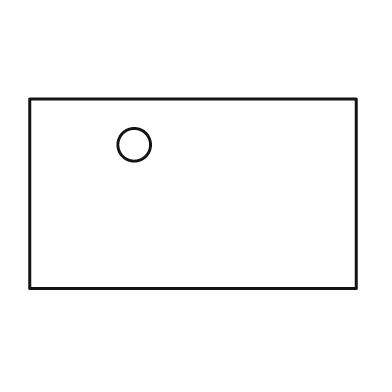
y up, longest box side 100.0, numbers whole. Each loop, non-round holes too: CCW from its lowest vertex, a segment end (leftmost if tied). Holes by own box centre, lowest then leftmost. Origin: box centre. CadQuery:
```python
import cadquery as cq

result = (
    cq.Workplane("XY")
    .moveTo(-50.0, -29.0)
    .lineTo(50.0, -29.0)
    .lineTo(50.0, 29.0)
    .lineTo(-50.0, 29.0)
    .close()
    .moveTo(-18.0, 15.0)
    .circle(5.0)
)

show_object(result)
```